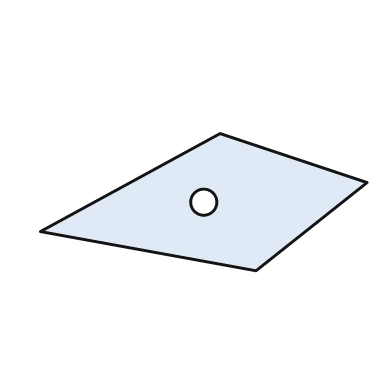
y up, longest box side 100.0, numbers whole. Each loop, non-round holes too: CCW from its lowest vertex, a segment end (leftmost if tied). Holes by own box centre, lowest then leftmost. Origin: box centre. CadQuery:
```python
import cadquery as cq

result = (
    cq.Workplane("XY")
    .moveTo(16.0, -21.0)
    .lineTo(50.0, 6.0)
    .lineTo(5.0, 21.0)
    .lineTo(-50.0, -9.0)
    .close()
    .moveTo(0.0, 0.0)
    .circle(4.0)
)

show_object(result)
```